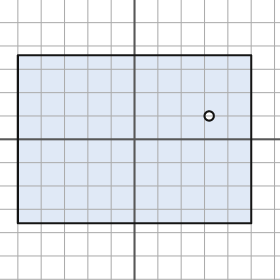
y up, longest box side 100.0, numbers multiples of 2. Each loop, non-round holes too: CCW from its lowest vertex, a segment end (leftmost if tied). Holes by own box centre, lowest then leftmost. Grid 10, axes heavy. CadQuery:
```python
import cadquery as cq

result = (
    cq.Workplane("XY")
    .moveTo(-50.0, -36.0)
    .lineTo(50.0, -36.0)
    .lineTo(50.0, 36.0)
    .lineTo(-50.0, 36.0)
    .close()
    .moveTo(32.0, 10.0)
    .circle(2.0)
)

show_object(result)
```